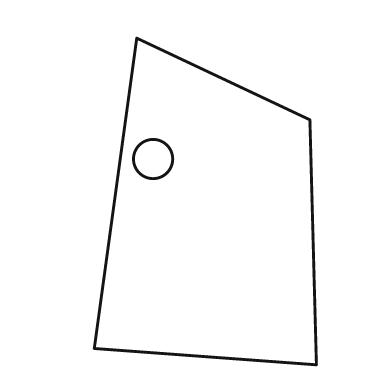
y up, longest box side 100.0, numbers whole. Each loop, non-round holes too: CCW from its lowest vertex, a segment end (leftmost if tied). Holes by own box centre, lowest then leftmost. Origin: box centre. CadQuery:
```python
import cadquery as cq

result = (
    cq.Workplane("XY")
    .moveTo(34.0, -50.0)
    .lineTo(32.0, 25.0)
    .lineTo(-21.0, 50.0)
    .lineTo(-34.0, -45.0)
    .close()
    .moveTo(-16.0, 13.0)
    .circle(6.0)
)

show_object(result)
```